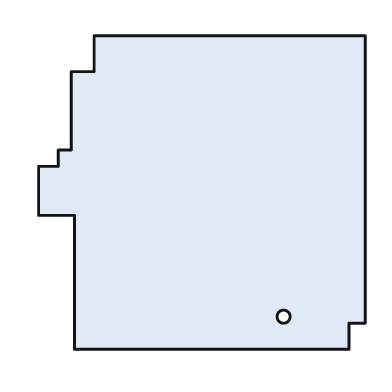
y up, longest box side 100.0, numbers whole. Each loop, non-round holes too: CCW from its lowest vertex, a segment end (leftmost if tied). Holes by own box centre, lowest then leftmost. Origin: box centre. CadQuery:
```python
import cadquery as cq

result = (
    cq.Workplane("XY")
    .moveTo(-39.0, -48.0)
    .lineTo(45.0, -48.0)
    .lineTo(45.0, -40.0)
    .lineTo(50.0, -40.0)
    .lineTo(50.0, 48.0)
    .lineTo(-33.0, 48.0)
    .lineTo(-33.0, 37.0)
    .lineTo(-40.0, 37.0)
    .lineTo(-40.0, 13.0)
    .lineTo(-44.0, 13.0)
    .lineTo(-44.0, 8.0)
    .lineTo(-50.0, 8.0)
    .lineTo(-50.0, -7.0)
    .lineTo(-39.0, -7.0)
    .close()
    .moveTo(25.0, -38.0)
    .circle(2.0)
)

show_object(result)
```